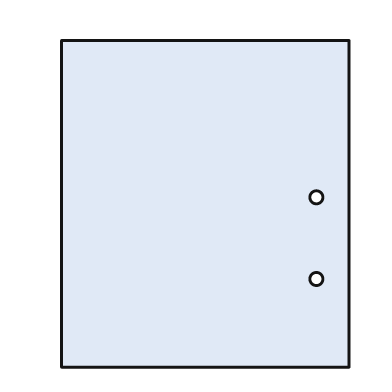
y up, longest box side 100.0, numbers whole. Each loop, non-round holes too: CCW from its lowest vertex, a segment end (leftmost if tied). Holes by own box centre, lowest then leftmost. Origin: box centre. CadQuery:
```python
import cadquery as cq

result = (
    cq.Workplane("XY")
    .moveTo(-44.0, -50.0)
    .lineTo(44.0, -50.0)
    .lineTo(44.0, 50.0)
    .lineTo(-44.0, 50.0)
    .close()
    .moveTo(34.0, -23.0)
    .circle(2.0)
    .moveTo(34.0, 2.0)
    .circle(2.0)
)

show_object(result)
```